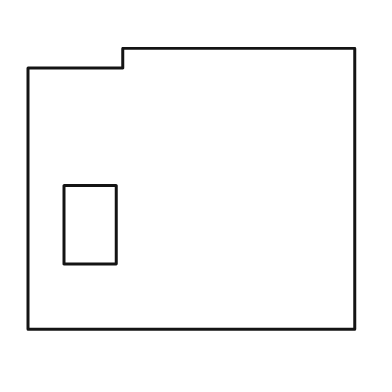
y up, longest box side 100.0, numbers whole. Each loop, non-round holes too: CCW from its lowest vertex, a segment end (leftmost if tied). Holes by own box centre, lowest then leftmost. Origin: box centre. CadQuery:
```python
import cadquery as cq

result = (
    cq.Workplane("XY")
    .moveTo(-50.0, -43.0)
    .lineTo(50.0, -43.0)
    .lineTo(50.0, 43.0)
    .lineTo(-21.0, 43.0)
    .lineTo(-21.0, 37.0)
    .lineTo(-50.0, 37.0)
    .close()
    .moveTo(-39.0, -23.0)
    .lineTo(-23.0, -23.0)
    .lineTo(-23.0, 1.0)
    .lineTo(-39.0, 1.0)
    .close()
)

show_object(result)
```